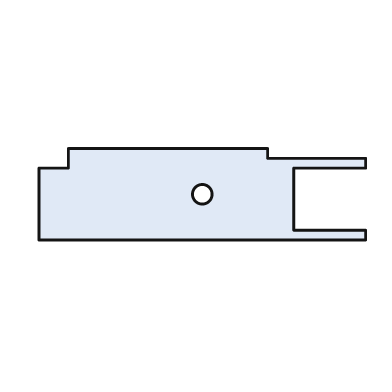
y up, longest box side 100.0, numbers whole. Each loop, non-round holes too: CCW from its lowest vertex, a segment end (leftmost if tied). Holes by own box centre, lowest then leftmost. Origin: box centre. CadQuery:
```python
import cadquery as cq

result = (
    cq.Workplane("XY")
    .moveTo(-50.0, -14.0)
    .lineTo(50.0, -14.0)
    .lineTo(50.0, -11.0)
    .lineTo(28.0, -11.0)
    .lineTo(28.0, 8.0)
    .lineTo(50.0, 8.0)
    .lineTo(50.0, 11.0)
    .lineTo(20.0, 11.0)
    .lineTo(20.0, 14.0)
    .lineTo(-41.0, 14.0)
    .lineTo(-41.0, 8.0)
    .lineTo(-50.0, 8.0)
    .close()
    .moveTo(0.0, 0.0)
    .circle(3.0)
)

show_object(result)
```